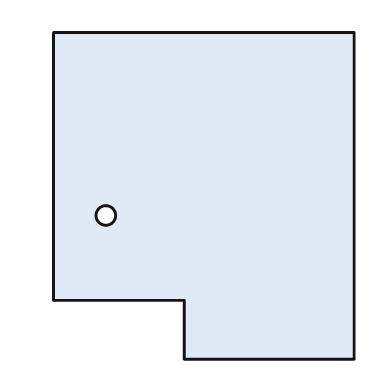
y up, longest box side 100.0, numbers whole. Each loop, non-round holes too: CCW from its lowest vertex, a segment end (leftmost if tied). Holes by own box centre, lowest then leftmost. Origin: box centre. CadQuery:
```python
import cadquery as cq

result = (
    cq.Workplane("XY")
    .moveTo(-6.0, -50.0)
    .lineTo(46.0, -50.0)
    .lineTo(46.0, 50.0)
    .lineTo(-46.0, 50.0)
    .lineTo(-46.0, -32.0)
    .lineTo(-6.0, -32.0)
    .close()
    .moveTo(-30.0, -6.0)
    .circle(3.0)
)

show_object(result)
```